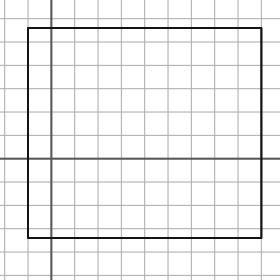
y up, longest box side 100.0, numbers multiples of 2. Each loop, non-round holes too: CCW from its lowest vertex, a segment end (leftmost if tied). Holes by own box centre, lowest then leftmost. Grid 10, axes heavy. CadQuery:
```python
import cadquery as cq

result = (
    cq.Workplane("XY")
    .moveTo(-10.0, -34.0)
    .lineTo(90.0, -34.0)
    .lineTo(90.0, 56.0)
    .lineTo(-10.0, 56.0)
    .close()
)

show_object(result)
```